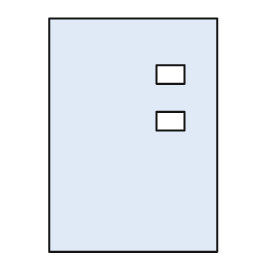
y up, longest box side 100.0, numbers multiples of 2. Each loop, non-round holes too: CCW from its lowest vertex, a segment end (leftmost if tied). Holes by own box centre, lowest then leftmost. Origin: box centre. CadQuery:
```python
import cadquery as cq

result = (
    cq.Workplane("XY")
    .moveTo(-36.0, -50.0)
    .lineTo(36.0, -50.0)
    .lineTo(36.0, 50.0)
    .lineTo(-36.0, 50.0)
    .close()
    .moveTo(10.0, 2.0)
    .lineTo(22.0, 2.0)
    .lineTo(22.0, 10.0)
    .lineTo(10.0, 10.0)
    .close()
    .moveTo(10.0, 22.0)
    .lineTo(22.0, 22.0)
    .lineTo(22.0, 30.0)
    .lineTo(10.0, 30.0)
    .close()
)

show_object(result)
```